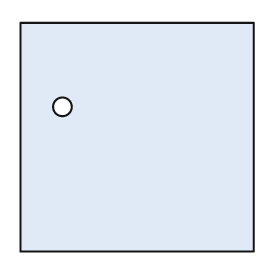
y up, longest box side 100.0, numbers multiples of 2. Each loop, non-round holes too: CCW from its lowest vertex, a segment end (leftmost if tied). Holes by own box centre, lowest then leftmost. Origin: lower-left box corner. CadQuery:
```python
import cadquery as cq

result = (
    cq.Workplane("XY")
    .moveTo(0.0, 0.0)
    .lineTo(100.0, 0.0)
    .lineTo(100.0, 98.0)
    .lineTo(0.0, 98.0)
    .close()
    .moveTo(18.0, 62.0)
    .circle(4.0)
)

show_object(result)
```